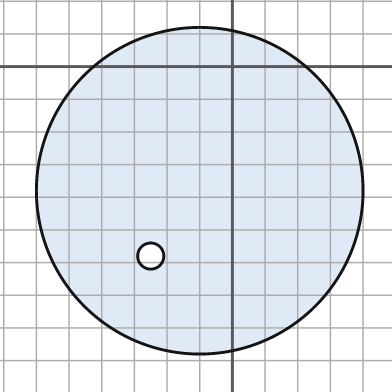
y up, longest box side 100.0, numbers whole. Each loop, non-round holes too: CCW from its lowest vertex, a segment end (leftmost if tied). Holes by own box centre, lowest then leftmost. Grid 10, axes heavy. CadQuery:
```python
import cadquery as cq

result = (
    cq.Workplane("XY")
    .moveTo(-10.0, -38.0)
    .circle(50.0)
    .moveTo(-25.0, -58.0)
    .circle(4.0)
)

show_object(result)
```